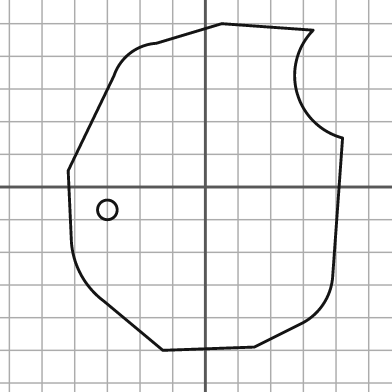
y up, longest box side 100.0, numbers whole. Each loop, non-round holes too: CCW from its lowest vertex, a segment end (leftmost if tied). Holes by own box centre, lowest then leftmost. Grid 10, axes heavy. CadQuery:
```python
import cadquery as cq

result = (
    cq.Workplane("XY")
    .moveTo(-13.0, -50.0)
    .lineTo(15.0, -49.0)
    .lineTo(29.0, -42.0)
    .threePointArc((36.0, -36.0), (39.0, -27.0))
    .lineTo(42.0, 15.0)
    .threePointArc((28.0, 29.0), (33.0, 48.0))
    .lineTo(5.0, 50.0)
    .lineTo(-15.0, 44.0)
    .threePointArc((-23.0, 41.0), (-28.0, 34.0))
    .lineTo(-42.0, 5.0)
    .lineTo(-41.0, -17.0)
    .threePointArc((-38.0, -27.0), (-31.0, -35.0))
    .close()
    .moveTo(-30.0, -7.0)
    .circle(3.0)
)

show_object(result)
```